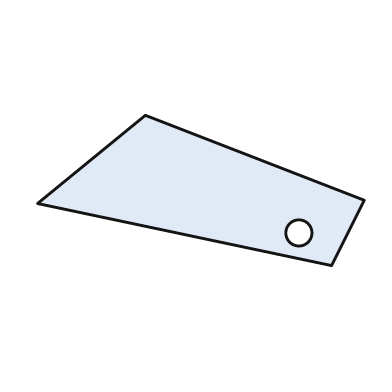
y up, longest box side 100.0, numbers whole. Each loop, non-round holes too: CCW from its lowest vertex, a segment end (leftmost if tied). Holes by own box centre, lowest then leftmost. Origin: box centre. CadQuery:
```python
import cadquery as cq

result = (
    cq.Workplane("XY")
    .moveTo(40.0, -23.0)
    .lineTo(50.0, -3.0)
    .lineTo(-17.0, 23.0)
    .lineTo(-50.0, -4.0)
    .close()
    .moveTo(30.0, -13.0)
    .circle(4.0)
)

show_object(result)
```